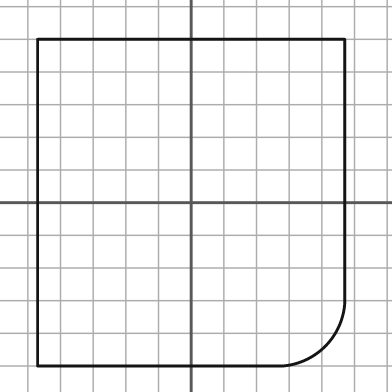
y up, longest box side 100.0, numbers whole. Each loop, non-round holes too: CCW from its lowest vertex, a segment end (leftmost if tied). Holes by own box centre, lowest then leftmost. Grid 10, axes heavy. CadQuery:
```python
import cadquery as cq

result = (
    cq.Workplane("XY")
    .moveTo(-47.0, -50.0)
    .lineTo(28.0, -50.0)
    .threePointArc((41.0, -44.0), (47.0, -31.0))
    .lineTo(47.0, 50.0)
    .lineTo(-47.0, 50.0)
    .close()
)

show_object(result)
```